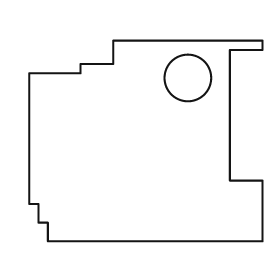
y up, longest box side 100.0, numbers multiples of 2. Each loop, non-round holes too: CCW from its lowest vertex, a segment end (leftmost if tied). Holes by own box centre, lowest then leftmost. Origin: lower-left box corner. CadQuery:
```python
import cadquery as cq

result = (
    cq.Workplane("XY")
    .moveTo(8.0, 0.0)
    .lineTo(100.0, 0.0)
    .lineTo(100.0, 26.0)
    .lineTo(86.0, 26.0)
    .lineTo(86.0, 82.0)
    .lineTo(100.0, 82.0)
    .lineTo(100.0, 86.0)
    .lineTo(36.0, 86.0)
    .lineTo(36.0, 76.0)
    .lineTo(22.0, 76.0)
    .lineTo(22.0, 72.0)
    .lineTo(0.0, 72.0)
    .lineTo(0.0, 16.0)
    .lineTo(4.0, 16.0)
    .lineTo(4.0, 8.0)
    .lineTo(8.0, 8.0)
    .close()
    .moveTo(68.0, 70.0)
    .circle(10.0)
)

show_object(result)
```